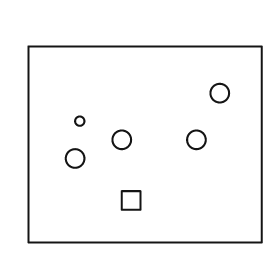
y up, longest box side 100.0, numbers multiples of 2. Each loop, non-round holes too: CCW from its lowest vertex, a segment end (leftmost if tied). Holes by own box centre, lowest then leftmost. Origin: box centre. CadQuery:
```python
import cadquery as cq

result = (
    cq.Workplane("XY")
    .moveTo(-50.0, -42.0)
    .lineTo(50.0, -42.0)
    .lineTo(50.0, 42.0)
    .lineTo(-50.0, 42.0)
    .close()
    .moveTo(-10.0, -28.0)
    .lineTo(-2.0, -28.0)
    .lineTo(-2.0, -20.0)
    .lineTo(-10.0, -20.0)
    .close()
    .moveTo(-30.0, -6.0)
    .circle(4.0)
    .moveTo(-10.0, 2.0)
    .circle(4.0)
    .moveTo(22.0, 2.0)
    .circle(4.0)
    .moveTo(-28.0, 10.0)
    .circle(2.0)
    .moveTo(32.0, 22.0)
    .circle(4.0)
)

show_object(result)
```